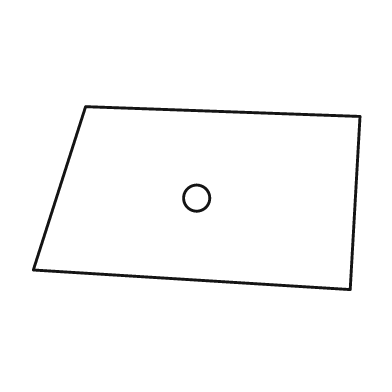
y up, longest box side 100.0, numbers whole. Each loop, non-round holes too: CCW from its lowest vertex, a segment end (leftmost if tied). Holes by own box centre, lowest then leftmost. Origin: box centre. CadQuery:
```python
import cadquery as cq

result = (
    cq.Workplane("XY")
    .moveTo(47.0, -28.0)
    .lineTo(50.0, 25.0)
    .lineTo(-34.0, 28.0)
    .lineTo(-50.0, -22.0)
    .close()
    .moveTo(0.0, 0.0)
    .circle(4.0)
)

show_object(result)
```